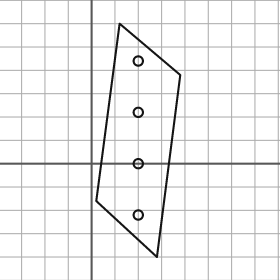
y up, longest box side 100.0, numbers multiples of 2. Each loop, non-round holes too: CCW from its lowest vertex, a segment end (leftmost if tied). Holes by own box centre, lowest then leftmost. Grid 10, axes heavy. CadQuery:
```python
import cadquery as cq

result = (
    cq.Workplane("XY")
    .moveTo(28.0, -40.0)
    .lineTo(38.0, 38.0)
    .lineTo(12.0, 60.0)
    .lineTo(2.0, -16.0)
    .close()
    .moveTo(20.0, -22.0)
    .circle(2.0)
    .moveTo(20.0, 0.0)
    .circle(2.0)
    .moveTo(20.0, 22.0)
    .circle(2.0)
    .moveTo(20.0, 44.0)
    .circle(2.0)
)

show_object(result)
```